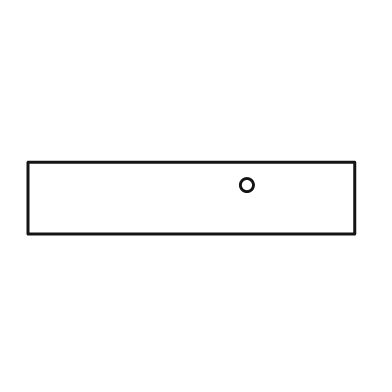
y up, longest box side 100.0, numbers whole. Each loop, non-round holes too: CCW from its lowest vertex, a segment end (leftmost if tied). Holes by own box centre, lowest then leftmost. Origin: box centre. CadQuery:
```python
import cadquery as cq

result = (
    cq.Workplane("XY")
    .moveTo(-50.0, -11.0)
    .lineTo(50.0, -11.0)
    .lineTo(50.0, 11.0)
    .lineTo(-50.0, 11.0)
    .close()
    .moveTo(17.0, 4.0)
    .circle(2.0)
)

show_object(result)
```